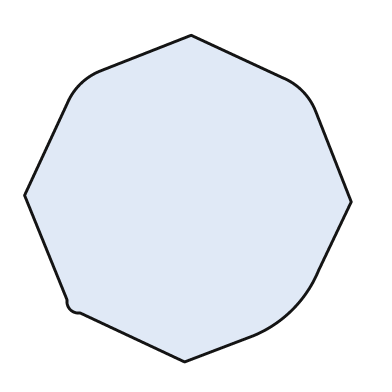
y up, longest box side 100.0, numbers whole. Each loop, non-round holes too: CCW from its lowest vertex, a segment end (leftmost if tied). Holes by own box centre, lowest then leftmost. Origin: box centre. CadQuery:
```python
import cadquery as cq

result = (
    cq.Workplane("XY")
    .moveTo(-1.0, -50.0)
    .lineTo(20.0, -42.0)
    .threePointArc((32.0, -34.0), (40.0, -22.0))
    .lineTo(50.0, -1.0)
    .lineTo(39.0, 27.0)
    .threePointArc((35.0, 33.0), (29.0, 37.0))
    .lineTo(1.0, 50.0)
    .lineTo(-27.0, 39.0)
    .threePointArc((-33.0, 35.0), (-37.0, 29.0))
    .lineTo(-50.0, 1.0)
    .lineTo(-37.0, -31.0)
    .threePointArc((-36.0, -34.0), (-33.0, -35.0))
    .close()
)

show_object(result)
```